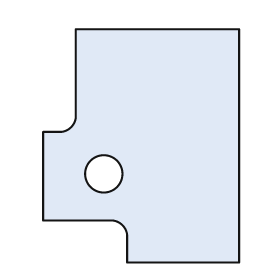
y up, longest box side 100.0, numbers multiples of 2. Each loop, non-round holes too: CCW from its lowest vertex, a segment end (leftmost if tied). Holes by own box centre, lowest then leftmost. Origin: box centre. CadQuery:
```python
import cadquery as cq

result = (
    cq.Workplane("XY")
    .moveTo(-6.0, -50.0)
    .lineTo(42.0, -50.0)
    .lineTo(42.0, 50.0)
    .lineTo(-28.0, 50.0)
    .lineTo(-28.0, 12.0)
    .threePointArc((-30.0, 8.0), (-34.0, 6.0))
    .lineTo(-42.0, 6.0)
    .lineTo(-42.0, -32.0)
    .lineTo(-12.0, -32.0)
    .threePointArc((-8.0, -34.0), (-6.0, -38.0))
    .close()
    .moveTo(-16.0, -12.0)
    .circle(8.0)
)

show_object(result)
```